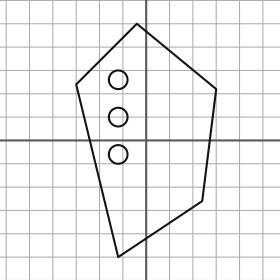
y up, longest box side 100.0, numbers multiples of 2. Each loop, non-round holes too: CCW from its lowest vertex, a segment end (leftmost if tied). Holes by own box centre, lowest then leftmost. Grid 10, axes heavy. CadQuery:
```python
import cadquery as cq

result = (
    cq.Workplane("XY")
    .moveTo(-12.0, -50.0)
    .lineTo(24.0, -26.0)
    .lineTo(30.0, 22.0)
    .lineTo(-4.0, 50.0)
    .lineTo(-30.0, 24.0)
    .close()
    .moveTo(-12.0, -6.0)
    .circle(4.0)
    .moveTo(-12.0, 10.0)
    .circle(4.0)
    .moveTo(-12.0, 26.0)
    .circle(4.0)
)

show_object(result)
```